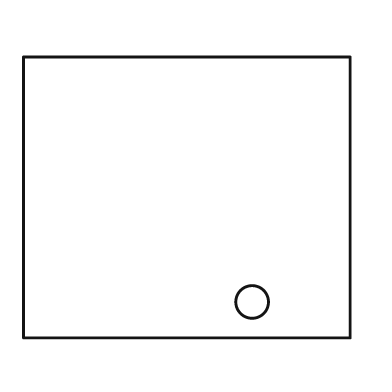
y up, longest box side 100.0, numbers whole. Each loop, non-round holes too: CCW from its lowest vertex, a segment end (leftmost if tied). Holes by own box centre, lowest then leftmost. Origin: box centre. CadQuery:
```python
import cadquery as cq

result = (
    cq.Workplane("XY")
    .moveTo(-50.0, -43.0)
    .lineTo(50.0, -43.0)
    .lineTo(50.0, 43.0)
    .lineTo(-50.0, 43.0)
    .close()
    .moveTo(20.0, -32.0)
    .circle(5.0)
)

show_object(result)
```